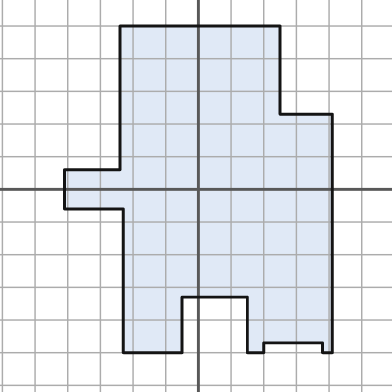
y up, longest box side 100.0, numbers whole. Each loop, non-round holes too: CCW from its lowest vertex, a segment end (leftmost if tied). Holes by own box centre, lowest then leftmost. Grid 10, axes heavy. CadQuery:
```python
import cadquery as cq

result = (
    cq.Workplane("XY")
    .moveTo(-23.0, -50.0)
    .lineTo(-5.0, -50.0)
    .lineTo(-5.0, -33.0)
    .lineTo(15.0, -33.0)
    .lineTo(15.0, -50.0)
    .lineTo(20.0, -50.0)
    .lineTo(20.0, -47.0)
    .lineTo(38.0, -47.0)
    .lineTo(38.0, -50.0)
    .lineTo(41.0, -50.0)
    .lineTo(41.0, 23.0)
    .lineTo(25.0, 23.0)
    .lineTo(25.0, 50.0)
    .lineTo(-24.0, 50.0)
    .lineTo(-24.0, 6.0)
    .lineTo(-41.0, 6.0)
    .lineTo(-41.0, -6.0)
    .lineTo(-23.0, -6.0)
    .close()
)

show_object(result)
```